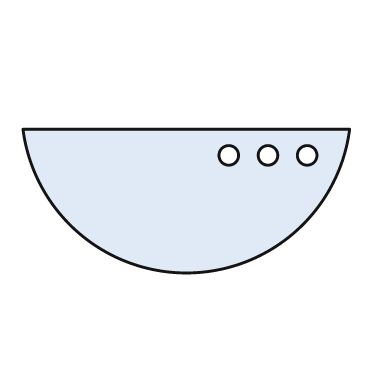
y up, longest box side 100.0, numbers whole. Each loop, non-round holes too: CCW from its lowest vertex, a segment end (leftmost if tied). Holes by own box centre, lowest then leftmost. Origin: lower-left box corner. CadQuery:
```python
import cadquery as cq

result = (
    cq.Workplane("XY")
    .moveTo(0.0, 44.0)
    .threePointArc((50.0, 0.0), (100.0, 44.0))
    .close()
    .moveTo(63.0, 36.0)
    .circle(3.0)
    .moveTo(75.0, 36.0)
    .circle(3.0)
    .moveTo(87.0, 36.0)
    .circle(3.0)
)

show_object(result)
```